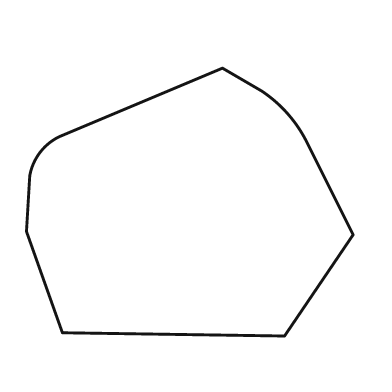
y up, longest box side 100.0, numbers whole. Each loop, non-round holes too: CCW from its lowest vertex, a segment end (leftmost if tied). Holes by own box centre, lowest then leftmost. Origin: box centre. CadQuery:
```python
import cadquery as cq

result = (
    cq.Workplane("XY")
    .moveTo(29.0, -41.0)
    .lineTo(50.0, -10.0)
    .lineTo(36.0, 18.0)
    .threePointArc((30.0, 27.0), (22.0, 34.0))
    .lineTo(10.0, 41.0)
    .lineTo(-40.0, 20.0)
    .threePointArc((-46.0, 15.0), (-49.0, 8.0))
    .lineTo(-50.0, -9.0)
    .lineTo(-39.0, -40.0)
    .close()
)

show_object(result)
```